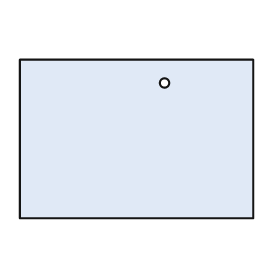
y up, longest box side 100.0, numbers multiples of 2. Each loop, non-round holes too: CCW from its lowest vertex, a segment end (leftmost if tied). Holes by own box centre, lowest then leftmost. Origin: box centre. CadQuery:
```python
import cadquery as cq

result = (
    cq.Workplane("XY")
    .moveTo(-50.0, -34.0)
    .lineTo(50.0, -34.0)
    .lineTo(50.0, 34.0)
    .lineTo(-50.0, 34.0)
    .close()
    .moveTo(12.0, 24.0)
    .circle(2.0)
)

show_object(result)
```